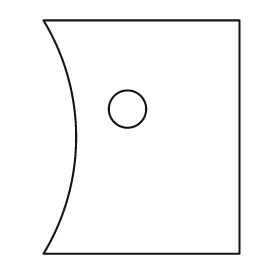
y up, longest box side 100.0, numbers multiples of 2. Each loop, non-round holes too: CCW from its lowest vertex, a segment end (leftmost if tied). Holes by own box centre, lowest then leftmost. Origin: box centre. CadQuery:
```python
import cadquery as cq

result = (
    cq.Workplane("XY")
    .moveTo(-42.0, -50.0)
    .lineTo(42.0, -50.0)
    .lineTo(42.0, 50.0)
    .lineTo(-42.0, 50.0)
    .threePointArc((-28.0, 0.0), (-42.0, -50.0))
    .close()
    .moveTo(-6.0, 12.0)
    .circle(8.0)
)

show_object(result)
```